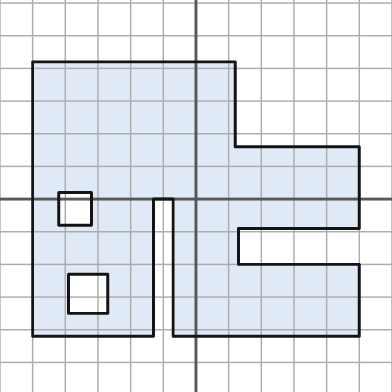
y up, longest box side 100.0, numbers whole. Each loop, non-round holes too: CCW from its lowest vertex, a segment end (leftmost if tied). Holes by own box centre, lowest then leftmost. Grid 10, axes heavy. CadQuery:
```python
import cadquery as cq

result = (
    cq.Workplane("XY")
    .moveTo(-50.0, -42.0)
    .lineTo(-13.0, -42.0)
    .lineTo(-13.0, 0.0)
    .lineTo(-7.0, 0.0)
    .lineTo(-7.0, -42.0)
    .lineTo(50.0, -42.0)
    .lineTo(50.0, -20.0)
    .lineTo(13.0, -20.0)
    .lineTo(13.0, -9.0)
    .lineTo(50.0, -9.0)
    .lineTo(50.0, 16.0)
    .lineTo(12.0, 16.0)
    .lineTo(12.0, 42.0)
    .lineTo(-50.0, 42.0)
    .close()
    .moveTo(-39.0, -35.0)
    .lineTo(-27.0, -35.0)
    .lineTo(-27.0, -23.0)
    .lineTo(-39.0, -23.0)
    .close()
    .moveTo(-42.0, -8.0)
    .lineTo(-32.0, -8.0)
    .lineTo(-32.0, 2.0)
    .lineTo(-42.0, 2.0)
    .close()
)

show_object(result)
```